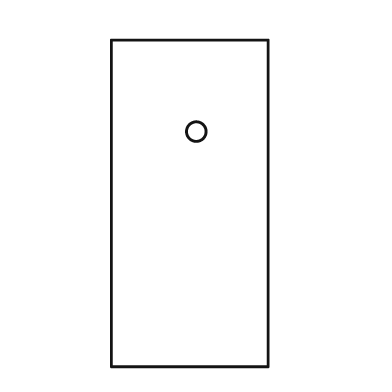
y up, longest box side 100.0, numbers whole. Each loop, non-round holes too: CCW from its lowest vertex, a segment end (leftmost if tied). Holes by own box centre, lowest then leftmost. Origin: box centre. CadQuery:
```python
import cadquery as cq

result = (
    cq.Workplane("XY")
    .moveTo(-24.0, -50.0)
    .lineTo(24.0, -50.0)
    .lineTo(24.0, 50.0)
    .lineTo(-24.0, 50.0)
    .close()
    .moveTo(2.0, 22.0)
    .circle(3.0)
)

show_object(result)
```